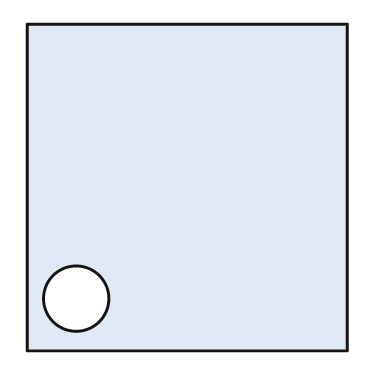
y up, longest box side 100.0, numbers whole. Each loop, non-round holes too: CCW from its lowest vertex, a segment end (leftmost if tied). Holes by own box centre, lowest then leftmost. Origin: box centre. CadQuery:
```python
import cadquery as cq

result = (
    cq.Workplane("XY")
    .moveTo(-49.0, -50.0)
    .lineTo(49.0, -50.0)
    .lineTo(49.0, 50.0)
    .lineTo(-49.0, 50.0)
    .close()
    .moveTo(-34.0, -34.0)
    .circle(10.0)
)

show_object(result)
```